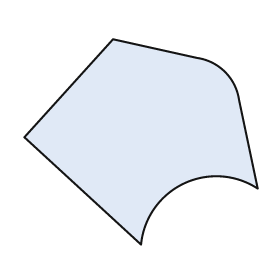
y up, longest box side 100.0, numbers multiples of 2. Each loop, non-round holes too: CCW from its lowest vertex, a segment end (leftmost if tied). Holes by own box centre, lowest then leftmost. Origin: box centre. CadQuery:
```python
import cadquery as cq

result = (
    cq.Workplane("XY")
    .moveTo(0.0, -44.0)
    .threePointArc((18.0, -18.0), (50.0, -20.0))
    .lineTo(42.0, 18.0)
    .threePointArc((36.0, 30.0), (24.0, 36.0))
    .lineTo(-12.0, 44.0)
    .lineTo(-50.0, 2.0)
    .close()
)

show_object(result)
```